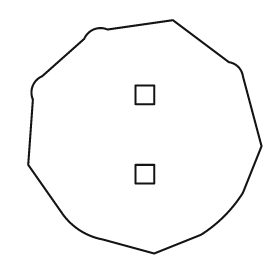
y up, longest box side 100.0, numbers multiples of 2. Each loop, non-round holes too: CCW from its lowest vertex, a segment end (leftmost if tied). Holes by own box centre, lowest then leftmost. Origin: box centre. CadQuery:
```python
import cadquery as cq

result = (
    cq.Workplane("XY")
    .moveTo(4.0, -50.0)
    .lineTo(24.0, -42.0)
    .threePointArc((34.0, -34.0), (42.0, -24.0))
    .lineTo(50.0, -4.0)
    .lineTo(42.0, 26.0)
    .threePointArc((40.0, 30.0), (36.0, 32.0))
    .lineTo(12.0, 50.0)
    .lineTo(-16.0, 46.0)
    .threePointArc((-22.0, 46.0), (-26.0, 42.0))
    .lineTo(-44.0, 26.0)
    .threePointArc((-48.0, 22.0), (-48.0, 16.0))
    .lineTo(-50.0, -12.0)
    .lineTo(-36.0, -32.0)
    .threePointArc((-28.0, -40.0), (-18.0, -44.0))
    .close()
    .moveTo(-4.0, -20.0)
    .lineTo(4.0, -20.0)
    .lineTo(4.0, -12.0)
    .lineTo(-4.0, -12.0)
    .close()
    .moveTo(-4.0, 14.0)
    .lineTo(4.0, 14.0)
    .lineTo(4.0, 22.0)
    .lineTo(-4.0, 22.0)
    .close()
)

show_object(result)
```